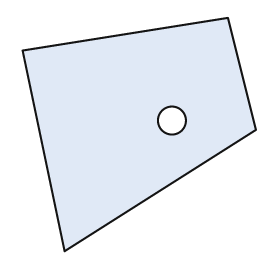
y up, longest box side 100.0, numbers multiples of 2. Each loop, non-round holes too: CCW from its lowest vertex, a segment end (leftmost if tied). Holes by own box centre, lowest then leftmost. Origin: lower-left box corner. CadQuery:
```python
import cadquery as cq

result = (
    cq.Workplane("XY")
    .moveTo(18.0, 0.0)
    .lineTo(100.0, 52.0)
    .lineTo(88.0, 100.0)
    .lineTo(0.0, 86.0)
    .close()
    .moveTo(64.0, 56.0)
    .circle(6.0)
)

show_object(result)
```